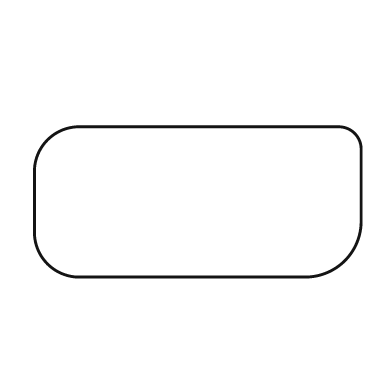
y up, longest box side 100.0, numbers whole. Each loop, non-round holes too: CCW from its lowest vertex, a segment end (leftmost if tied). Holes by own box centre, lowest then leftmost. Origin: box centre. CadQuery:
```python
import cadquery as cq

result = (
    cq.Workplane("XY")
    .moveTo(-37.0, -23.0)
    .lineTo(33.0, -23.0)
    .threePointArc((45.0, -18.0), (50.0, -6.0))
    .lineTo(50.0, 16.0)
    .threePointArc((48.0, 21.0), (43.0, 23.0))
    .lineTo(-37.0, 23.0)
    .threePointArc((-46.0, 19.0), (-50.0, 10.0))
    .lineTo(-50.0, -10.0)
    .threePointArc((-46.0, -19.0), (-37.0, -23.0))
    .close()
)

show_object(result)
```